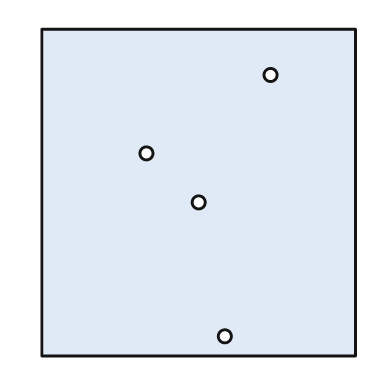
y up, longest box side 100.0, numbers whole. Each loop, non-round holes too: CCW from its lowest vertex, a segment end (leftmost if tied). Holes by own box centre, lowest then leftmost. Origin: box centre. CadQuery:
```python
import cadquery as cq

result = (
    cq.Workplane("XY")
    .moveTo(-48.0, -50.0)
    .lineTo(48.0, -50.0)
    .lineTo(48.0, 50.0)
    .lineTo(-48.0, 50.0)
    .close()
    .moveTo(8.0, -44.0)
    .circle(2.0)
    .moveTo(0.0, -3.0)
    .circle(2.0)
    .moveTo(-16.0, 12.0)
    .circle(2.0)
    .moveTo(22.0, 36.0)
    .circle(2.0)
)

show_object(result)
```